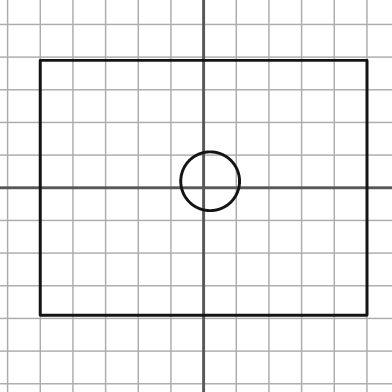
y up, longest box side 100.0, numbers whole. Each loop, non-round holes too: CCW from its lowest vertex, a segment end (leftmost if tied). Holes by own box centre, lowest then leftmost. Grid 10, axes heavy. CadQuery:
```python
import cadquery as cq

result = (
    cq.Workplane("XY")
    .moveTo(-50.0, -39.0)
    .lineTo(50.0, -39.0)
    .lineTo(50.0, 39.0)
    .lineTo(-50.0, 39.0)
    .close()
    .moveTo(2.0, 2.0)
    .circle(9.0)
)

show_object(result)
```